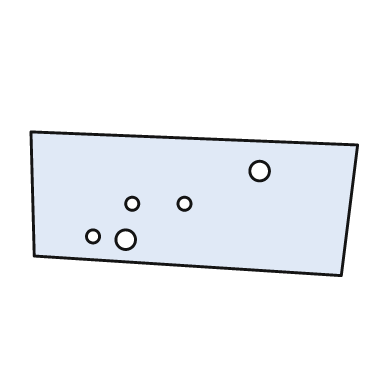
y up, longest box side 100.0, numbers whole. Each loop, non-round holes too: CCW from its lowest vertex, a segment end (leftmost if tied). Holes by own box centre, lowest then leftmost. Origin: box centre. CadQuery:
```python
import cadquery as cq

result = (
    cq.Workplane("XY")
    .moveTo(45.0, -22.0)
    .lineTo(50.0, 18.0)
    .lineTo(-50.0, 22.0)
    .lineTo(-49.0, -16.0)
    .close()
    .moveTo(-21.0, -11.0)
    .circle(3.0)
    .moveTo(-31.0, -10.0)
    .circle(2.0)
    .moveTo(-19.0, 0.0)
    .circle(2.0)
    .moveTo(-3.0, 0.0)
    .circle(2.0)
    .moveTo(20.0, 10.0)
    .circle(3.0)
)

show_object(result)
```